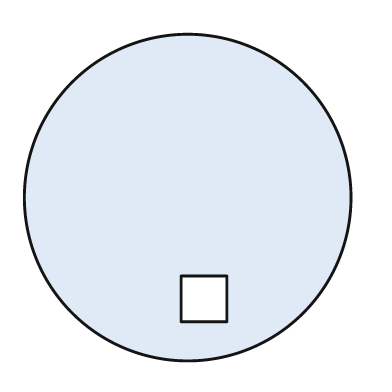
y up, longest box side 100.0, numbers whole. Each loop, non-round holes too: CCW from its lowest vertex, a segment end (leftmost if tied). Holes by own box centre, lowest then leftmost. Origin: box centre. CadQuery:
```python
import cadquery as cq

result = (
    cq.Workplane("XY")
    .moveTo(0.0, 0.0)
    .circle(50.0)
    .moveTo(-2.0, -38.0)
    .lineTo(12.0, -38.0)
    .lineTo(12.0, -24.0)
    .lineTo(-2.0, -24.0)
    .close()
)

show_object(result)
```